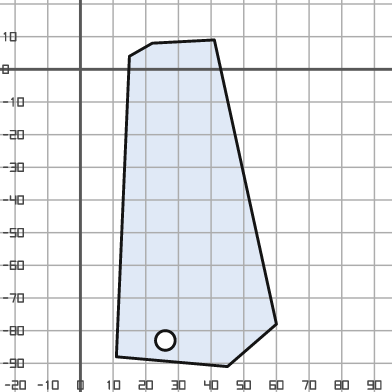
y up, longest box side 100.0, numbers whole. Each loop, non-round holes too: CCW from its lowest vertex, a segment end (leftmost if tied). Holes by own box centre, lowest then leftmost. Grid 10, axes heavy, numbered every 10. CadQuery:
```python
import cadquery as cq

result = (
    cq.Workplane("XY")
    .moveTo(45.0, -91.0)
    .lineTo(60.0, -78.0)
    .lineTo(41.0, 9.0)
    .lineTo(22.0, 8.0)
    .lineTo(15.0, 4.0)
    .lineTo(11.0, -88.0)
    .close()
    .moveTo(26.0, -83.0)
    .circle(3.0)
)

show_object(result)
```